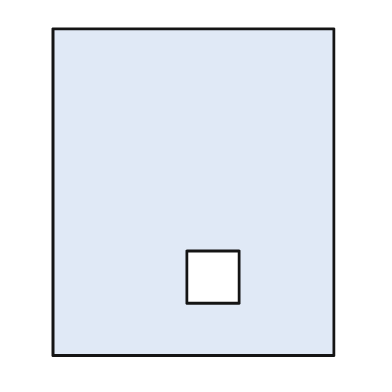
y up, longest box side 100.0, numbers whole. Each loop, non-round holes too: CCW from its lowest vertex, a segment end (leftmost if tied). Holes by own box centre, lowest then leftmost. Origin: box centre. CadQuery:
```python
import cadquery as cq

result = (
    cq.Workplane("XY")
    .moveTo(-43.0, -50.0)
    .lineTo(43.0, -50.0)
    .lineTo(43.0, 50.0)
    .lineTo(-43.0, 50.0)
    .close()
    .moveTo(-2.0, -34.0)
    .lineTo(14.0, -34.0)
    .lineTo(14.0, -18.0)
    .lineTo(-2.0, -18.0)
    .close()
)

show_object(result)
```